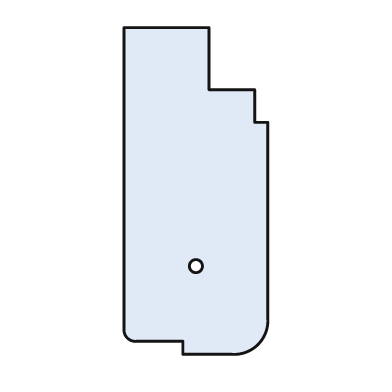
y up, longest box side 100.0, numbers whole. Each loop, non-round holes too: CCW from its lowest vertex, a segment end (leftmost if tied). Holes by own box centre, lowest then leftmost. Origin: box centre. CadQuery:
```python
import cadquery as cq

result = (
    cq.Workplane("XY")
    .moveTo(-4.0, -50.0)
    .lineTo(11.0, -50.0)
    .threePointArc((19.0, -47.0), (22.0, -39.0))
    .lineTo(22.0, 21.0)
    .lineTo(18.0, 21.0)
    .lineTo(18.0, 31.0)
    .lineTo(4.0, 31.0)
    .lineTo(4.0, 50.0)
    .lineTo(-22.0, 50.0)
    .lineTo(-22.0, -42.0)
    .threePointArc((-21.0, -45.0), (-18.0, -46.0))
    .lineTo(-4.0, -46.0)
    .close()
    .moveTo(0.0, -23.0)
    .circle(2.0)
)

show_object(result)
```